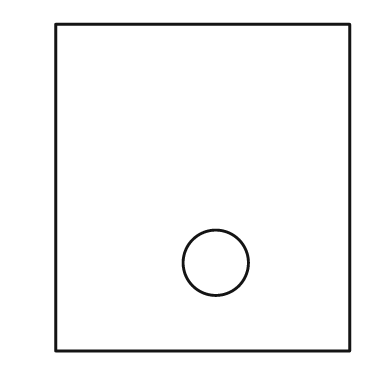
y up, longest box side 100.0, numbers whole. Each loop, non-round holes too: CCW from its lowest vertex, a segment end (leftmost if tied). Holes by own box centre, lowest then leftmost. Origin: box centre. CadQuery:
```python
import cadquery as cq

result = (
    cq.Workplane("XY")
    .moveTo(-45.0, -50.0)
    .lineTo(45.0, -50.0)
    .lineTo(45.0, 50.0)
    .lineTo(-45.0, 50.0)
    .close()
    .moveTo(4.0, -23.0)
    .circle(10.0)
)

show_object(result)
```